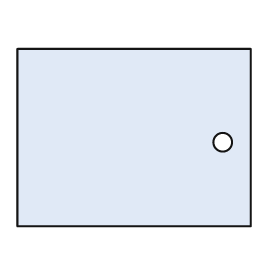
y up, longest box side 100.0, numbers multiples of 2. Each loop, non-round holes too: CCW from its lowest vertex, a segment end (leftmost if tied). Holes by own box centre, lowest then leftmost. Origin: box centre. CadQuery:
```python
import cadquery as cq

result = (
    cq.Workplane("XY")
    .moveTo(-50.0, -38.0)
    .lineTo(50.0, -38.0)
    .lineTo(50.0, 38.0)
    .lineTo(-50.0, 38.0)
    .close()
    .moveTo(38.0, -2.0)
    .circle(4.0)
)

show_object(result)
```